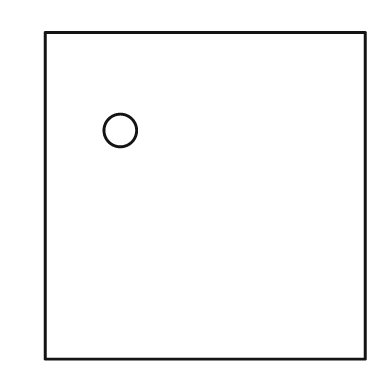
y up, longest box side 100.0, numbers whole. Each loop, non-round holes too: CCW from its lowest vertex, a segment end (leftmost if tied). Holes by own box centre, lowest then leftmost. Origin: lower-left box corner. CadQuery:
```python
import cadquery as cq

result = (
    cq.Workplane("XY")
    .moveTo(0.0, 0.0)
    .lineTo(98.0, 0.0)
    .lineTo(98.0, 100.0)
    .lineTo(0.0, 100.0)
    .close()
    .moveTo(23.0, 70.0)
    .circle(5.0)
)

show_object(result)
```